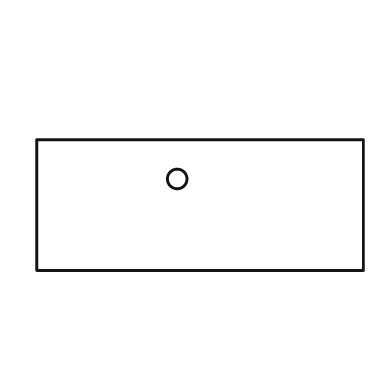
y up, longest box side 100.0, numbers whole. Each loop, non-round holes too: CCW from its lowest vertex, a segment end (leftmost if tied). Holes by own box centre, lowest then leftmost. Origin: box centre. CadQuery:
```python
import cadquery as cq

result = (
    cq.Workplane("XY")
    .moveTo(-50.0, -20.0)
    .lineTo(50.0, -20.0)
    .lineTo(50.0, 20.0)
    .lineTo(-50.0, 20.0)
    .close()
    .moveTo(-7.0, 8.0)
    .circle(3.0)
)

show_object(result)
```